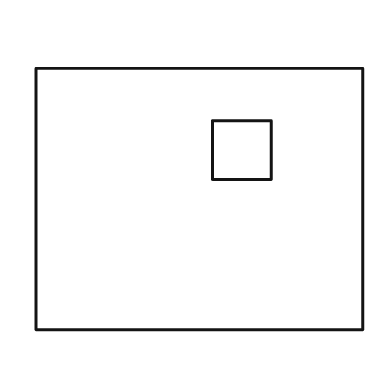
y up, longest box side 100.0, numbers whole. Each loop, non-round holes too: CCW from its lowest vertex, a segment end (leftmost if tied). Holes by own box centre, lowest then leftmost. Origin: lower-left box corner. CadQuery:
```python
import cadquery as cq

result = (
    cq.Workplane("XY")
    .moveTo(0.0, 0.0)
    .lineTo(100.0, 0.0)
    .lineTo(100.0, 80.0)
    .lineTo(0.0, 80.0)
    .close()
    .moveTo(54.0, 46.0)
    .lineTo(72.0, 46.0)
    .lineTo(72.0, 64.0)
    .lineTo(54.0, 64.0)
    .close()
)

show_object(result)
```